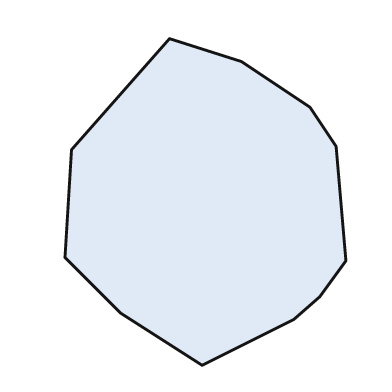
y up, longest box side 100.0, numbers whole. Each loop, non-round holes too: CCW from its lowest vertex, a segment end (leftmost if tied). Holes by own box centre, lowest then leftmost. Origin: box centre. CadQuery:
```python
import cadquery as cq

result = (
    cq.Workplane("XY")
    .moveTo(-1.0, -50.0)
    .lineTo(27.0, -36.0)
    .lineTo(35.0, -29.0)
    .lineTo(43.0, -18.0)
    .lineTo(40.0, 17.0)
    .lineTo(32.0, 29.0)
    .lineTo(11.0, 43.0)
    .lineTo(-11.0, 50.0)
    .lineTo(-41.0, 16.0)
    .lineTo(-43.0, -17.0)
    .lineTo(-26.0, -34.0)
    .close()
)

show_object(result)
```